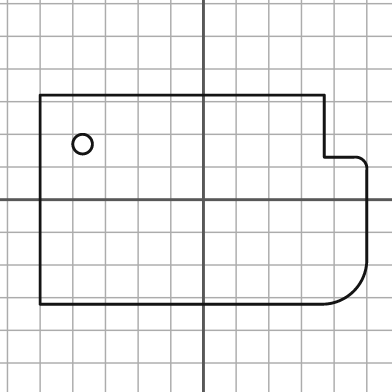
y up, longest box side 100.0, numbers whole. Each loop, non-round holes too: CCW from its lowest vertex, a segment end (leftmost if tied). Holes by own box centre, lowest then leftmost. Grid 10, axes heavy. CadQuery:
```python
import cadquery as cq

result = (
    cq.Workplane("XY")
    .moveTo(-50.0, -32.0)
    .lineTo(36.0, -32.0)
    .threePointArc((46.0, -28.0), (50.0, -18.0))
    .lineTo(50.0, 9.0)
    .threePointArc((49.0, 12.0), (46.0, 13.0))
    .lineTo(37.0, 13.0)
    .lineTo(37.0, 32.0)
    .lineTo(-50.0, 32.0)
    .close()
    .moveTo(-37.0, 17.0)
    .circle(3.0)
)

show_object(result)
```